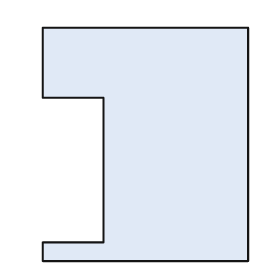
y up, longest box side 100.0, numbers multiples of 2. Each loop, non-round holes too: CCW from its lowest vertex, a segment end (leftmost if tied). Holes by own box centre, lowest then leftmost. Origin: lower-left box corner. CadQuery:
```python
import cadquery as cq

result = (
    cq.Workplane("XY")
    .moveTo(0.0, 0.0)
    .lineTo(88.0, 0.0)
    .lineTo(88.0, 100.0)
    .lineTo(0.0, 100.0)
    .lineTo(0.0, 70.0)
    .lineTo(26.0, 70.0)
    .lineTo(26.0, 8.0)
    .lineTo(0.0, 8.0)
    .close()
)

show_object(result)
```